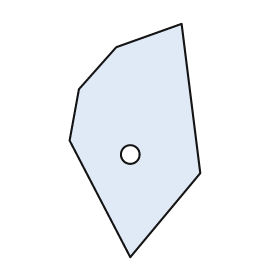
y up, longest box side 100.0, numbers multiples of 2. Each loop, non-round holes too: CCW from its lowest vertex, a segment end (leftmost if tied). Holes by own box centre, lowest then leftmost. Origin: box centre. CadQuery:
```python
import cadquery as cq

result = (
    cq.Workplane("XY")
    .moveTo(-2.0, -50.0)
    .lineTo(28.0, -14.0)
    .lineTo(20.0, 50.0)
    .lineTo(-8.0, 40.0)
    .lineTo(-24.0, 22.0)
    .lineTo(-28.0, 0.0)
    .close()
    .moveTo(-2.0, -6.0)
    .circle(4.0)
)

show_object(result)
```